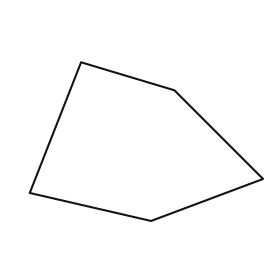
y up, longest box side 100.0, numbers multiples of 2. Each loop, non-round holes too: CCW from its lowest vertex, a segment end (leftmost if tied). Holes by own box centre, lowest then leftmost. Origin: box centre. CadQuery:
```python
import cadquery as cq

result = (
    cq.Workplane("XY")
    .moveTo(2.0, -34.0)
    .lineTo(50.0, -16.0)
    .lineTo(12.0, 22.0)
    .lineTo(-28.0, 34.0)
    .lineTo(-50.0, -22.0)
    .close()
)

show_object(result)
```